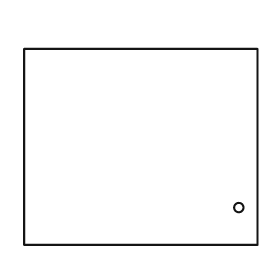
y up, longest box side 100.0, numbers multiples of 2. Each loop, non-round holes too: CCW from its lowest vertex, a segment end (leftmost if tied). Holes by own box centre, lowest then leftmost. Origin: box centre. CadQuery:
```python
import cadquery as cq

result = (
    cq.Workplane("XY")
    .moveTo(-50.0, -42.0)
    .lineTo(50.0, -42.0)
    .lineTo(50.0, 42.0)
    .lineTo(-50.0, 42.0)
    .close()
    .moveTo(42.0, -26.0)
    .circle(2.0)
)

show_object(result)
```